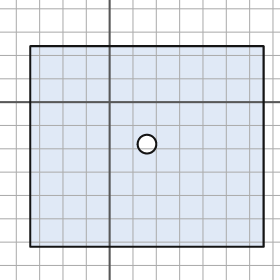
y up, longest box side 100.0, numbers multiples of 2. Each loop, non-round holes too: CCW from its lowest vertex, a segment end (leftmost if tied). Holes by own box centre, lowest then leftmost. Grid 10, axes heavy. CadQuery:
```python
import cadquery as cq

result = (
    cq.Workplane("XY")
    .moveTo(-34.0, -62.0)
    .lineTo(66.0, -62.0)
    .lineTo(66.0, 24.0)
    .lineTo(-34.0, 24.0)
    .close()
    .moveTo(16.0, -18.0)
    .circle(4.0)
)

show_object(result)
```